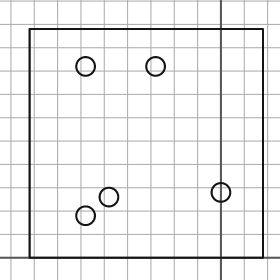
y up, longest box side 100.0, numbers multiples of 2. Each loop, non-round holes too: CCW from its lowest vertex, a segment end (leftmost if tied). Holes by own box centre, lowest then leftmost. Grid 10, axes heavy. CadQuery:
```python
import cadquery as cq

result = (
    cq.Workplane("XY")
    .moveTo(-82.0, 0.0)
    .lineTo(18.0, 0.0)
    .lineTo(18.0, 98.0)
    .lineTo(-82.0, 98.0)
    .close()
    .moveTo(-58.0, 18.0)
    .circle(4.0)
    .moveTo(-48.0, 26.0)
    .circle(4.0)
    .moveTo(0.0, 28.0)
    .circle(4.0)
    .moveTo(-58.0, 82.0)
    .circle(4.0)
    .moveTo(-28.0, 82.0)
    .circle(4.0)
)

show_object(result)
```